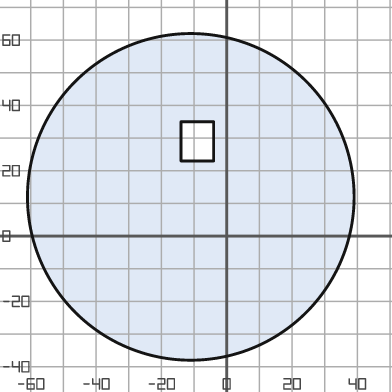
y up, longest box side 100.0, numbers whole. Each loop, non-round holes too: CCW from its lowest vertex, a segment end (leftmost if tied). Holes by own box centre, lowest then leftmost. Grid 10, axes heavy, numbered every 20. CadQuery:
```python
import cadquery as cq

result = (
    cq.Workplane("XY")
    .moveTo(-11.0, 12.0)
    .circle(50.0)
    .moveTo(-14.0, 23.0)
    .lineTo(-4.0, 23.0)
    .lineTo(-4.0, 35.0)
    .lineTo(-14.0, 35.0)
    .close()
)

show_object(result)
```